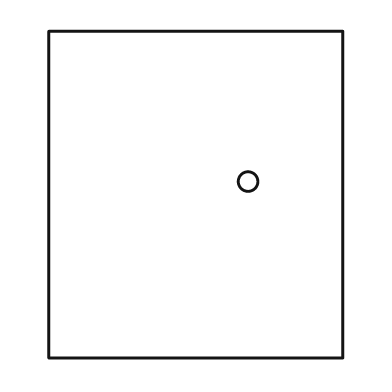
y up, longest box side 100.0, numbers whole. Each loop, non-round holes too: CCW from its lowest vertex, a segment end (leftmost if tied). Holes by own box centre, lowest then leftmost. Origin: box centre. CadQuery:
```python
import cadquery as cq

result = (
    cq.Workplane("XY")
    .moveTo(-45.0, -50.0)
    .lineTo(45.0, -50.0)
    .lineTo(45.0, 50.0)
    .lineTo(-45.0, 50.0)
    .close()
    .moveTo(16.0, 4.0)
    .circle(3.0)
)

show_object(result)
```